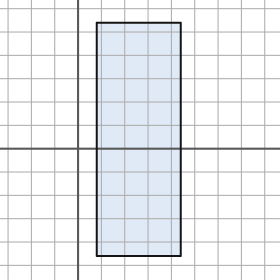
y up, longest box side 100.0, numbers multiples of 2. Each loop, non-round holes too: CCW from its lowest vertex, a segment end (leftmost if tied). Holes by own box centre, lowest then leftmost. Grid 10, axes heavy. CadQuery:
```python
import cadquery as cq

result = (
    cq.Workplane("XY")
    .moveTo(8.0, -46.0)
    .lineTo(44.0, -46.0)
    .lineTo(44.0, 54.0)
    .lineTo(8.0, 54.0)
    .close()
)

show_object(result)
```